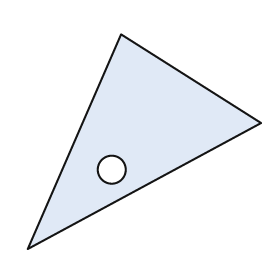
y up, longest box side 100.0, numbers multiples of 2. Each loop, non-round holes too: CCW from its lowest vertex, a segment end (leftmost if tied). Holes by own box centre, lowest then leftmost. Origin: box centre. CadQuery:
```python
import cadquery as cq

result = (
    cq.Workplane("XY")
    .moveTo(-50.0, -46.0)
    .lineTo(50.0, 8.0)
    .lineTo(-10.0, 46.0)
    .close()
    .moveTo(-14.0, -12.0)
    .circle(6.0)
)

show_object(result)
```